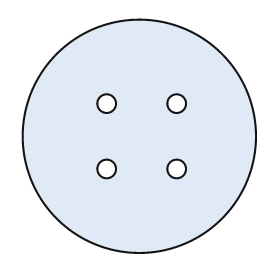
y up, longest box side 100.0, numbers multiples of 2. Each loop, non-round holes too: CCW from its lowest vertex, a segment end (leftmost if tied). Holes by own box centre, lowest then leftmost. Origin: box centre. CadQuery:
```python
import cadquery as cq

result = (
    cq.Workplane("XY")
    .moveTo(0.0, 0.0)
    .circle(50.0)
    .moveTo(-14.0, -14.0)
    .circle(4.0)
    .moveTo(16.0, -14.0)
    .circle(4.0)
    .moveTo(-14.0, 14.0)
    .circle(4.0)
    .moveTo(16.0, 14.0)
    .circle(4.0)
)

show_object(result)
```